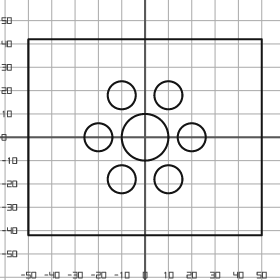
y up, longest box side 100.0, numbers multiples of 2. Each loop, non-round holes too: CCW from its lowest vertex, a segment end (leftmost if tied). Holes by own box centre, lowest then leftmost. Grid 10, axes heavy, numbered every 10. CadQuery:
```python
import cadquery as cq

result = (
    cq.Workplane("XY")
    .moveTo(-50.0, -42.0)
    .lineTo(50.0, -42.0)
    .lineTo(50.0, 42.0)
    .lineTo(-50.0, 42.0)
    .close()
    .moveTo(-10.0, -18.0)
    .circle(6.0)
    .moveTo(10.0, -18.0)
    .circle(6.0)
    .moveTo(-20.0, 0.0)
    .circle(6.0)
    .moveTo(0.0, 0.0)
    .circle(10.0)
    .moveTo(20.0, 0.0)
    .circle(6.0)
    .moveTo(-10.0, 18.0)
    .circle(6.0)
    .moveTo(10.0, 18.0)
    .circle(6.0)
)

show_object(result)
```